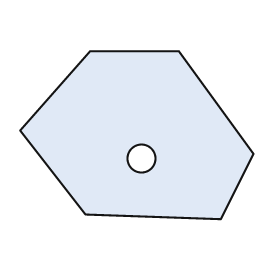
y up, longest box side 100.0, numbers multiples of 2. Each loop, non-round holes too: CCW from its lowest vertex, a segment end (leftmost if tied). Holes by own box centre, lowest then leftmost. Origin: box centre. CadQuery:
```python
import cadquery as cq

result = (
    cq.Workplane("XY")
    .moveTo(36.0, -36.0)
    .lineTo(50.0, -8.0)
    .lineTo(18.0, 36.0)
    .lineTo(-20.0, 36.0)
    .lineTo(-50.0, 2.0)
    .lineTo(-22.0, -34.0)
    .close()
    .moveTo(2.0, -10.0)
    .circle(6.0)
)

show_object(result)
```